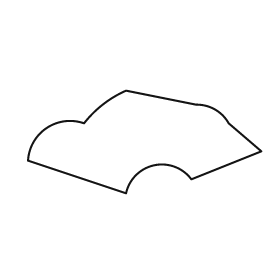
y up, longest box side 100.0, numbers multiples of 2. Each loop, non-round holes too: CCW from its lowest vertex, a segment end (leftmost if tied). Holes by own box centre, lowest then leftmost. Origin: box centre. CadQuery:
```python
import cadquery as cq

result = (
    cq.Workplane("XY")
    .moveTo(-8.0, -22.0)
    .threePointArc((4.0, -10.0), (20.0, -16.0))
    .lineTo(50.0, -4.0)
    .lineTo(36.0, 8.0)
    .threePointArc((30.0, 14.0), (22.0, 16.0))
    .lineTo(-8.0, 22.0)
    .threePointArc((-18.0, 16.0), (-26.0, 8.0))
    .threePointArc((-42.0, 6.0), (-50.0, -8.0))
    .close()
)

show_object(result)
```